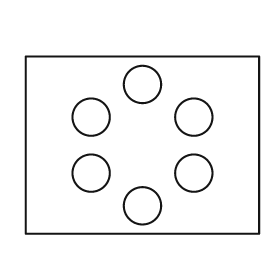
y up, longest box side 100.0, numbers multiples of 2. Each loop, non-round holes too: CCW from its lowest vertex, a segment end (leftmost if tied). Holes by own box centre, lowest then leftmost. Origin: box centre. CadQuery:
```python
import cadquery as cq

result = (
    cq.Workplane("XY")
    .moveTo(-50.0, -38.0)
    .lineTo(50.0, -38.0)
    .lineTo(50.0, 38.0)
    .lineTo(-50.0, 38.0)
    .close()
    .moveTo(0.0, -26.0)
    .circle(8.0)
    .moveTo(-22.0, -12.0)
    .circle(8.0)
    .moveTo(22.0, -12.0)
    .circle(8.0)
    .moveTo(-22.0, 12.0)
    .circle(8.0)
    .moveTo(22.0, 12.0)
    .circle(8.0)
    .moveTo(0.0, 26.0)
    .circle(8.0)
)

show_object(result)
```